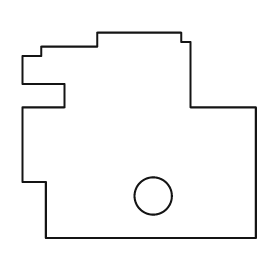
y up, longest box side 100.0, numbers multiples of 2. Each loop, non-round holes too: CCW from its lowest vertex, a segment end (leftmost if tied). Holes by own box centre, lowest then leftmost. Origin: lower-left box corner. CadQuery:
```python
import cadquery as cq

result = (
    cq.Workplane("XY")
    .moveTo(10.0, 0.0)
    .lineTo(100.0, 0.0)
    .lineTo(100.0, 56.0)
    .lineTo(72.0, 56.0)
    .lineTo(72.0, 84.0)
    .lineTo(68.0, 84.0)
    .lineTo(68.0, 88.0)
    .lineTo(32.0, 88.0)
    .lineTo(32.0, 82.0)
    .lineTo(8.0, 82.0)
    .lineTo(8.0, 78.0)
    .lineTo(0.0, 78.0)
    .lineTo(0.0, 66.0)
    .lineTo(18.0, 66.0)
    .lineTo(18.0, 56.0)
    .lineTo(0.0, 56.0)
    .lineTo(0.0, 24.0)
    .lineTo(10.0, 24.0)
    .close()
    .moveTo(56.0, 18.0)
    .circle(8.0)
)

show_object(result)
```